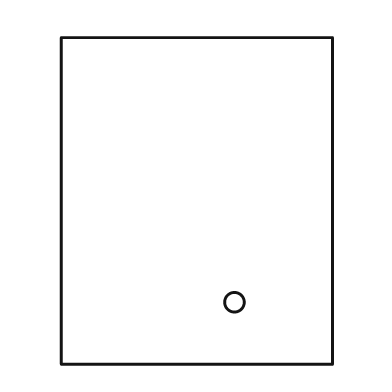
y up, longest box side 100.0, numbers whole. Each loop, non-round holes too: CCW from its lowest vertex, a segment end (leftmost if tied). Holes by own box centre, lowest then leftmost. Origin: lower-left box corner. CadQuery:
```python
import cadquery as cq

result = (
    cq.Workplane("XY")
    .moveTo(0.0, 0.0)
    .lineTo(83.0, 0.0)
    .lineTo(83.0, 100.0)
    .lineTo(0.0, 100.0)
    .close()
    .moveTo(53.0, 19.0)
    .circle(3.0)
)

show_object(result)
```